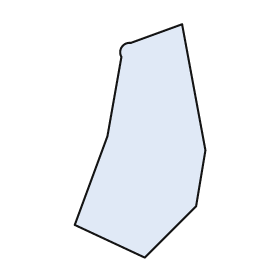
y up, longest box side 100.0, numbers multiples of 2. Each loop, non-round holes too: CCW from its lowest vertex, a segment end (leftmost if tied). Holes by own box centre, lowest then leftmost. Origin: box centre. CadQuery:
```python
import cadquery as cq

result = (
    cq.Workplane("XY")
    .moveTo(2.0, -50.0)
    .lineTo(24.0, -28.0)
    .lineTo(28.0, -4.0)
    .lineTo(18.0, 50.0)
    .lineTo(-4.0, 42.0)
    .threePointArc((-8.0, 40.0), (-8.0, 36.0))
    .lineTo(-14.0, 2.0)
    .lineTo(-28.0, -36.0)
    .close()
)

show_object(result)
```